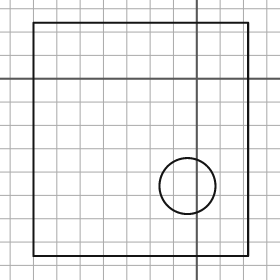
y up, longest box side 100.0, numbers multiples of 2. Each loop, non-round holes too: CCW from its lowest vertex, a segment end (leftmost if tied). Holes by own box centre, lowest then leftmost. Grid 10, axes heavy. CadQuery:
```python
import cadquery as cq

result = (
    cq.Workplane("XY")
    .moveTo(-70.0, -76.0)
    .lineTo(22.0, -76.0)
    .lineTo(22.0, 24.0)
    .lineTo(-70.0, 24.0)
    .close()
    .moveTo(-4.0, -46.0)
    .circle(12.0)
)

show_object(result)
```